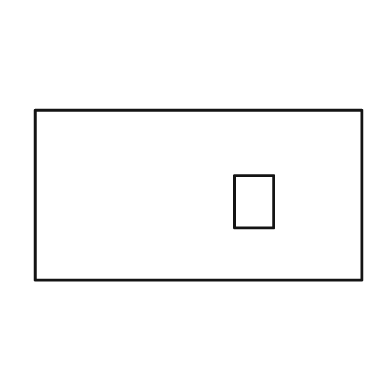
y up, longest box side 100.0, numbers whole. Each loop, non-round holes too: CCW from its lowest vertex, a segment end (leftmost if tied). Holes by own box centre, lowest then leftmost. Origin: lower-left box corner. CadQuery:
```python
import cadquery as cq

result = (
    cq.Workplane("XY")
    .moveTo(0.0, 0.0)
    .lineTo(100.0, 0.0)
    .lineTo(100.0, 52.0)
    .lineTo(0.0, 52.0)
    .close()
    .moveTo(61.0, 16.0)
    .lineTo(73.0, 16.0)
    .lineTo(73.0, 32.0)
    .lineTo(61.0, 32.0)
    .close()
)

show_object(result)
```